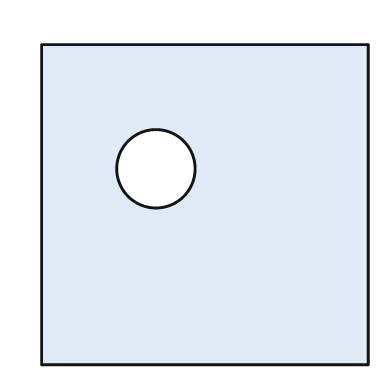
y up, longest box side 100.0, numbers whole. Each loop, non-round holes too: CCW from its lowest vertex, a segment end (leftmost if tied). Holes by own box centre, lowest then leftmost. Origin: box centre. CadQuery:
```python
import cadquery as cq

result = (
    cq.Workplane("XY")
    .moveTo(-50.0, -49.0)
    .lineTo(50.0, -49.0)
    .lineTo(50.0, 49.0)
    .lineTo(-50.0, 49.0)
    .close()
    .moveTo(-15.0, 11.0)
    .circle(12.0)
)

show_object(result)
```